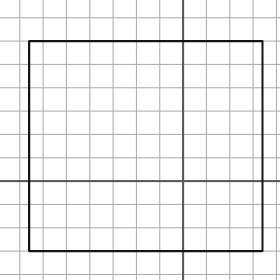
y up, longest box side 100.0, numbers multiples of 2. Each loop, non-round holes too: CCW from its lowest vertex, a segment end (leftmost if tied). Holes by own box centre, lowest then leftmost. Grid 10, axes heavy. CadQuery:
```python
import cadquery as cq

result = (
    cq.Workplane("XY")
    .moveTo(-66.0, -30.0)
    .lineTo(34.0, -30.0)
    .lineTo(34.0, 60.0)
    .lineTo(-66.0, 60.0)
    .close()
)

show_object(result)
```